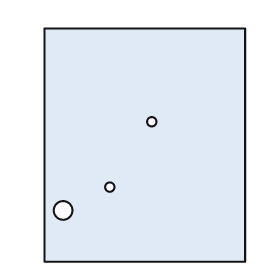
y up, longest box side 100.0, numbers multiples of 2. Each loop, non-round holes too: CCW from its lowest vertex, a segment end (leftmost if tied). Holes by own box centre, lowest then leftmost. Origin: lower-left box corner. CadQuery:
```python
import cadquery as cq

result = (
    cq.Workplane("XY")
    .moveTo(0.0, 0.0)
    .lineTo(86.0, 0.0)
    .lineTo(86.0, 100.0)
    .lineTo(0.0, 100.0)
    .close()
    .moveTo(8.0, 22.0)
    .circle(4.0)
    .moveTo(28.0, 32.0)
    .circle(2.0)
    .moveTo(46.0, 60.0)
    .circle(2.0)
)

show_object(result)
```